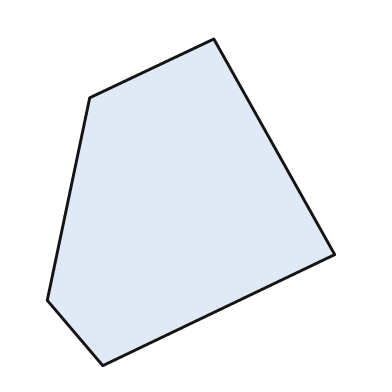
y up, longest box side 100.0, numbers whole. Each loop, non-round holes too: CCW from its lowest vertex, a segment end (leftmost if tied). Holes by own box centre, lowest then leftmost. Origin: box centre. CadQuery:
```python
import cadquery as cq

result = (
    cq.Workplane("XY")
    .moveTo(-27.0, -50.0)
    .lineTo(44.0, -16.0)
    .lineTo(7.0, 50.0)
    .lineTo(-31.0, 32.0)
    .lineTo(-44.0, -30.0)
    .close()
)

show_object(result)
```